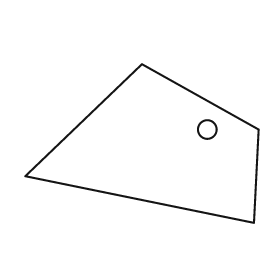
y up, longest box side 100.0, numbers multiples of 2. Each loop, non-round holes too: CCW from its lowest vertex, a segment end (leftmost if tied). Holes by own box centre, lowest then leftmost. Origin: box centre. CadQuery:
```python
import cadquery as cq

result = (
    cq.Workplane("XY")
    .moveTo(48.0, -34.0)
    .lineTo(50.0, 6.0)
    .lineTo(0.0, 34.0)
    .lineTo(-50.0, -14.0)
    .close()
    .moveTo(28.0, 6.0)
    .circle(4.0)
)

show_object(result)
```